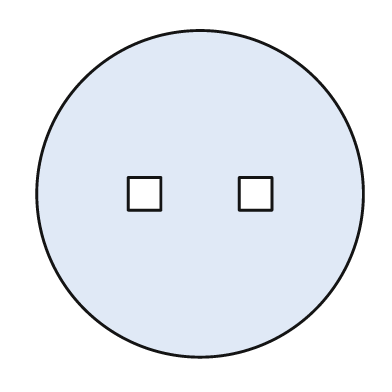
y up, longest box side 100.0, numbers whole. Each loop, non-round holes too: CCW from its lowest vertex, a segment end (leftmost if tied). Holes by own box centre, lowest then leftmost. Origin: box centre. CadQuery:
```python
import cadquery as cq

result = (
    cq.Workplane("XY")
    .moveTo(0.0, 0.0)
    .circle(50.0)
    .moveTo(-22.0, -5.0)
    .lineTo(-12.0, -5.0)
    .lineTo(-12.0, 5.0)
    .lineTo(-22.0, 5.0)
    .close()
    .moveTo(12.0, -5.0)
    .lineTo(22.0, -5.0)
    .lineTo(22.0, 5.0)
    .lineTo(12.0, 5.0)
    .close()
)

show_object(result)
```